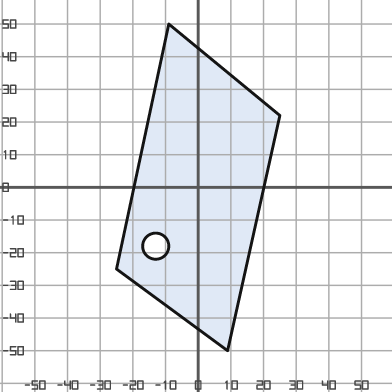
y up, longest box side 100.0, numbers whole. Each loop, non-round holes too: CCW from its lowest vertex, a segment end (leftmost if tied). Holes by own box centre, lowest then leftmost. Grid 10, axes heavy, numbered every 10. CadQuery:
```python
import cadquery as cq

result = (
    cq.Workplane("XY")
    .moveTo(9.0, -50.0)
    .lineTo(25.0, 22.0)
    .lineTo(-9.0, 50.0)
    .lineTo(-25.0, -25.0)
    .close()
    .moveTo(-13.0, -18.0)
    .circle(4.0)
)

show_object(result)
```